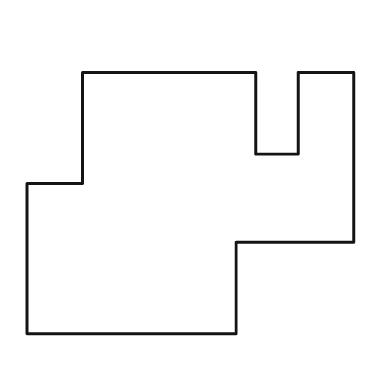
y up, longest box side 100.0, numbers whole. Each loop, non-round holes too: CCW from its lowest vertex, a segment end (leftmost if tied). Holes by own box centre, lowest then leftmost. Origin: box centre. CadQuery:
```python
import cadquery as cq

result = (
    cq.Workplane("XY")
    .moveTo(-50.0, -40.0)
    .lineTo(14.0, -40.0)
    .lineTo(14.0, -12.0)
    .lineTo(50.0, -12.0)
    .lineTo(50.0, 40.0)
    .lineTo(33.0, 40.0)
    .lineTo(33.0, 15.0)
    .lineTo(20.0, 15.0)
    .lineTo(20.0, 40.0)
    .lineTo(-33.0, 40.0)
    .lineTo(-33.0, 6.0)
    .lineTo(-50.0, 6.0)
    .close()
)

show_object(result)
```